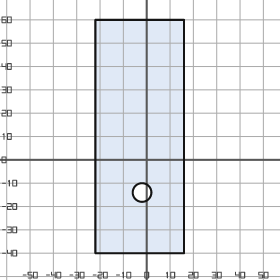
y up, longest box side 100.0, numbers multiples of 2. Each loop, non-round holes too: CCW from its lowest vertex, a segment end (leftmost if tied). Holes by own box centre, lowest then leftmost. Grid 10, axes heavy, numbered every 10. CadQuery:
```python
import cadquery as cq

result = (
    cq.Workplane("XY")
    .moveTo(-22.0, -40.0)
    .lineTo(16.0, -40.0)
    .lineTo(16.0, 60.0)
    .lineTo(-22.0, 60.0)
    .close()
    .moveTo(-2.0, -14.0)
    .circle(4.0)
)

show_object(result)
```